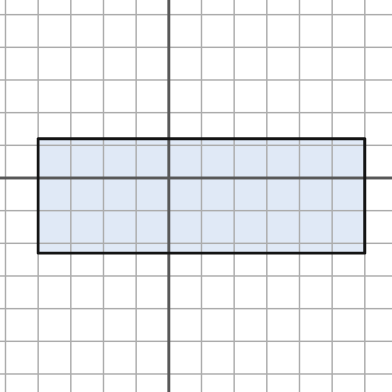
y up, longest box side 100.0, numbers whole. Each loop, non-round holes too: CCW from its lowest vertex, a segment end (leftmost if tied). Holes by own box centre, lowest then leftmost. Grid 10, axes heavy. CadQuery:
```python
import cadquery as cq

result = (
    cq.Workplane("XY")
    .moveTo(-40.0, -23.0)
    .lineTo(60.0, -23.0)
    .lineTo(60.0, 12.0)
    .lineTo(-40.0, 12.0)
    .close()
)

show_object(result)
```